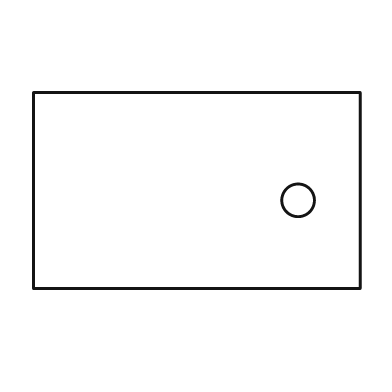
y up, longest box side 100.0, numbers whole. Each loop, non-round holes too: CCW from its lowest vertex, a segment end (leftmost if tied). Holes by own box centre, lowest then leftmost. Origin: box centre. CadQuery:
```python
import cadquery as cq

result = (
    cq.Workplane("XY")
    .moveTo(-50.0, -30.0)
    .lineTo(50.0, -30.0)
    .lineTo(50.0, 30.0)
    .lineTo(-50.0, 30.0)
    .close()
    .moveTo(31.0, -3.0)
    .circle(5.0)
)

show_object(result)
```